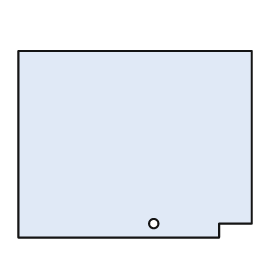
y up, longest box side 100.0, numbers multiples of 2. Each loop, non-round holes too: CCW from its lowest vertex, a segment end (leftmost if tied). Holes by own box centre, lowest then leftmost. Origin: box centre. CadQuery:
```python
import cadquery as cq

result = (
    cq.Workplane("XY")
    .moveTo(-50.0, -40.0)
    .lineTo(36.0, -40.0)
    .lineTo(36.0, -34.0)
    .lineTo(50.0, -34.0)
    .lineTo(50.0, 40.0)
    .lineTo(-50.0, 40.0)
    .close()
    .moveTo(8.0, -34.0)
    .circle(2.0)
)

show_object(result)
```